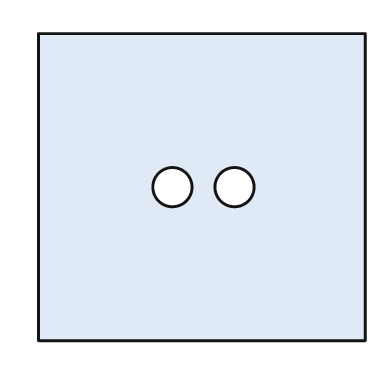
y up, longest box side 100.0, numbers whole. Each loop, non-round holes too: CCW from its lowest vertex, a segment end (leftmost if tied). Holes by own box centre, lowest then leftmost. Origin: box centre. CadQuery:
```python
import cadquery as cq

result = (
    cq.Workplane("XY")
    .moveTo(-50.0, -47.0)
    .lineTo(50.0, -47.0)
    .lineTo(50.0, 47.0)
    .lineTo(-50.0, 47.0)
    .close()
    .moveTo(-9.0, 0.0)
    .circle(6.0)
    .moveTo(10.0, 0.0)
    .circle(6.0)
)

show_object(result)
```